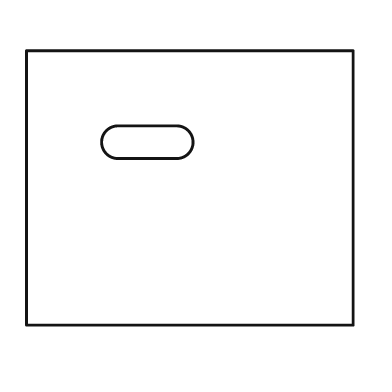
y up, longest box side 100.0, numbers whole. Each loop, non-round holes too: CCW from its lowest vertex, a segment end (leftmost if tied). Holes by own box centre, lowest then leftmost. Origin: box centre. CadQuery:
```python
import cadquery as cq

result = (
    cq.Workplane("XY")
    .moveTo(-50.0, -42.0)
    .lineTo(50.0, -42.0)
    .lineTo(50.0, 42.0)
    .lineTo(-50.0, 42.0)
    .close()
    .moveTo(-22.0, 9.0)
    .lineTo(-4.0, 9.0)
    .threePointArc((1.0, 14.0), (-4.0, 19.0))
    .lineTo(-22.0, 19.0)
    .threePointArc((-27.0, 14.0), (-22.0, 9.0))
    .close()
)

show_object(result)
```